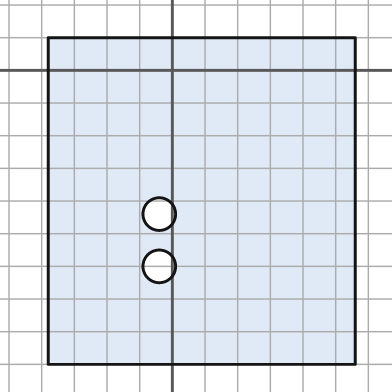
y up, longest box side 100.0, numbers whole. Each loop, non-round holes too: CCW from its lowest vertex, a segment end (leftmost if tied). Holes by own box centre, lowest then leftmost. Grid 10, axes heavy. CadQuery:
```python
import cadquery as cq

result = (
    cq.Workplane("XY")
    .moveTo(-38.0, -90.0)
    .lineTo(56.0, -90.0)
    .lineTo(56.0, 10.0)
    .lineTo(-38.0, 10.0)
    .close()
    .moveTo(-4.0, -60.0)
    .circle(5.0)
    .moveTo(-4.0, -44.0)
    .circle(5.0)
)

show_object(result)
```